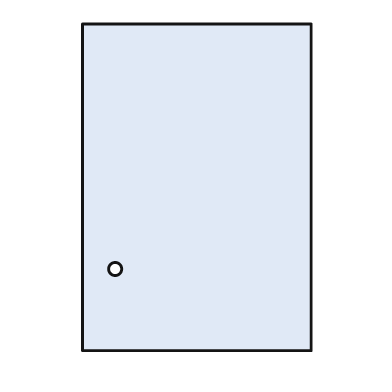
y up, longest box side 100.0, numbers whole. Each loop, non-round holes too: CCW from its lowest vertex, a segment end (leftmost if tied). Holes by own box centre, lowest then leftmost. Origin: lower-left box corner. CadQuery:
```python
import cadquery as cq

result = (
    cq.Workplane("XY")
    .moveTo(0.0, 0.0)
    .lineTo(70.0, 0.0)
    .lineTo(70.0, 100.0)
    .lineTo(0.0, 100.0)
    .close()
    .moveTo(10.0, 25.0)
    .circle(2.0)
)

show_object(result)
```